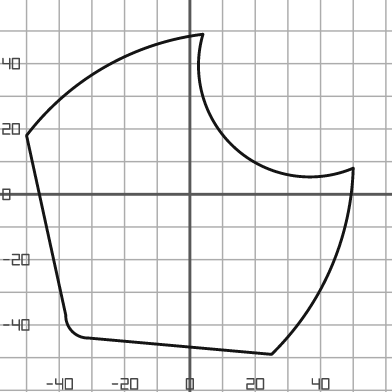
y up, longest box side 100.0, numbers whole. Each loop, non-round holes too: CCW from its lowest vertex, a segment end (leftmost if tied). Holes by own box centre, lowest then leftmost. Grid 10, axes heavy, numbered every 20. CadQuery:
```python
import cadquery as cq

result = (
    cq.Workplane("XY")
    .moveTo(25.0, -49.0)
    .threePointArc((43.0, -23.0), (50.0, 8.0))
    .threePointArc((14.0, 14.0), (4.0, 49.0))
    .threePointArc((-26.0, 39.0), (-50.0, 18.0))
    .lineTo(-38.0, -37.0)
    .threePointArc((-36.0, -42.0), (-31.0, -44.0))
    .close()
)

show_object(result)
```